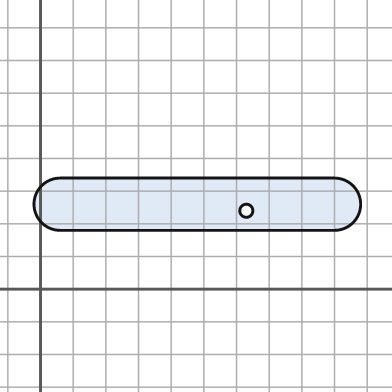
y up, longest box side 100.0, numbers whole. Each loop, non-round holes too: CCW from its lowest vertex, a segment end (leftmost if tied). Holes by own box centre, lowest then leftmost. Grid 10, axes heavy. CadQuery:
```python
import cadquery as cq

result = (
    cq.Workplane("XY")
    .moveTo(6.0, 18.0)
    .lineTo(90.0, 18.0)
    .threePointArc((98.0, 26.0), (90.0, 34.0))
    .lineTo(6.0, 34.0)
    .threePointArc((-2.0, 26.0), (6.0, 18.0))
    .close()
    .moveTo(63.0, 24.0)
    .circle(2.0)
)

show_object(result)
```